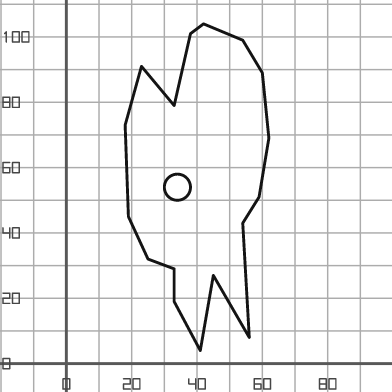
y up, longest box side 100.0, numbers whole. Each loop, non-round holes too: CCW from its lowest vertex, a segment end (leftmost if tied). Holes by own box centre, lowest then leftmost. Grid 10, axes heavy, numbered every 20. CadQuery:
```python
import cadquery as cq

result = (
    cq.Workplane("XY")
    .moveTo(41.0, 4.0)
    .lineTo(45.0, 27.0)
    .lineTo(56.0, 8.0)
    .lineTo(54.0, 43.0)
    .lineTo(59.0, 51.0)
    .lineTo(62.0, 69.0)
    .lineTo(60.0, 89.0)
    .lineTo(54.0, 99.0)
    .lineTo(42.0, 104.0)
    .lineTo(38.0, 101.0)
    .lineTo(33.0, 79.0)
    .lineTo(23.0, 91.0)
    .lineTo(18.0, 73.0)
    .lineTo(19.0, 45.0)
    .lineTo(25.0, 32.0)
    .lineTo(33.0, 29.0)
    .lineTo(33.0, 19.0)
    .close()
    .moveTo(34.0, 54.0)
    .circle(4.0)
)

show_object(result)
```